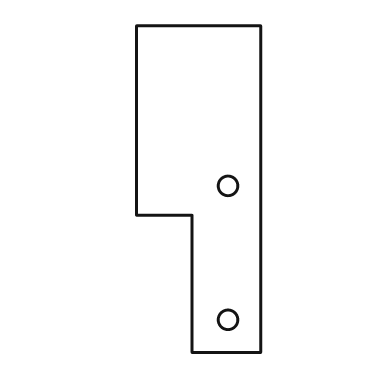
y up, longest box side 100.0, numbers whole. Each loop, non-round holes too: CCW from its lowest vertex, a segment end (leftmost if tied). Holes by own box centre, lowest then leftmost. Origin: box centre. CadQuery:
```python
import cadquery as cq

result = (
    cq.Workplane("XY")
    .moveTo(-2.0, -50.0)
    .lineTo(19.0, -50.0)
    .lineTo(19.0, 50.0)
    .lineTo(-19.0, 50.0)
    .lineTo(-19.0, -8.0)
    .lineTo(-2.0, -8.0)
    .close()
    .moveTo(9.0, -40.0)
    .circle(3.0)
    .moveTo(9.0, 1.0)
    .circle(3.0)
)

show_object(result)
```